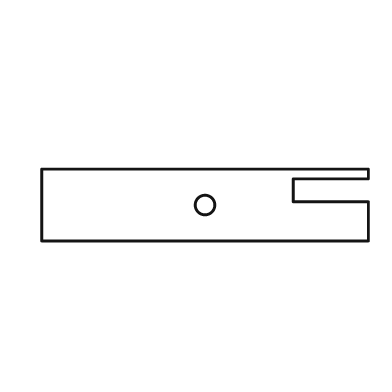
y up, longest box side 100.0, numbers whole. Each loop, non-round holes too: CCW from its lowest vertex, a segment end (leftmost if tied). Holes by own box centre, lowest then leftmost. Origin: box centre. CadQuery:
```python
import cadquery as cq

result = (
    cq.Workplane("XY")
    .moveTo(-50.0, -11.0)
    .lineTo(50.0, -11.0)
    .lineTo(50.0, 1.0)
    .lineTo(27.0, 1.0)
    .lineTo(27.0, 8.0)
    .lineTo(50.0, 8.0)
    .lineTo(50.0, 11.0)
    .lineTo(-50.0, 11.0)
    .close()
    .moveTo(0.0, 0.0)
    .circle(3.0)
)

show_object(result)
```